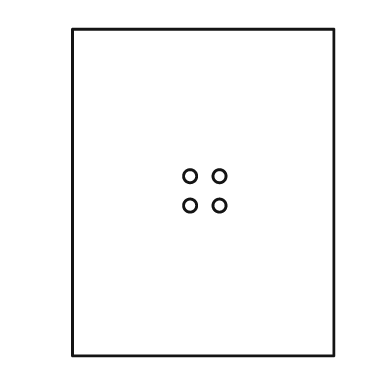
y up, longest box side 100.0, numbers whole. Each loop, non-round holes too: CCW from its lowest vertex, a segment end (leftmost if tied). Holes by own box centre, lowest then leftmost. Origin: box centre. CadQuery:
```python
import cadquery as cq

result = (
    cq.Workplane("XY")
    .moveTo(-40.0, -50.0)
    .lineTo(40.0, -50.0)
    .lineTo(40.0, 50.0)
    .lineTo(-40.0, 50.0)
    .close()
    .moveTo(-4.0, -4.0)
    .circle(2.0)
    .moveTo(5.0, -4.0)
    .circle(2.0)
    .moveTo(-4.0, 5.0)
    .circle(2.0)
    .moveTo(5.0, 5.0)
    .circle(2.0)
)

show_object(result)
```